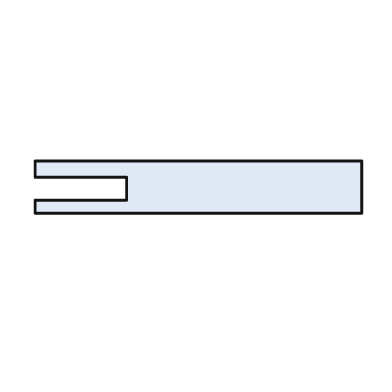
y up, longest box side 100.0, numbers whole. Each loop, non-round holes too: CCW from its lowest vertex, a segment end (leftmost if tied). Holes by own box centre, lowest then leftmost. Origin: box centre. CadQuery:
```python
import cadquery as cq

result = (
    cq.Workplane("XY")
    .moveTo(-50.0, -8.0)
    .lineTo(50.0, -8.0)
    .lineTo(50.0, 8.0)
    .lineTo(-50.0, 8.0)
    .lineTo(-50.0, 3.0)
    .lineTo(-22.0, 3.0)
    .lineTo(-22.0, -4.0)
    .lineTo(-50.0, -4.0)
    .close()
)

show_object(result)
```